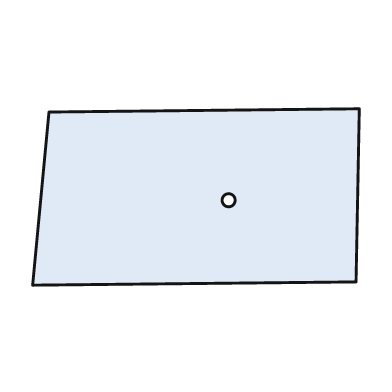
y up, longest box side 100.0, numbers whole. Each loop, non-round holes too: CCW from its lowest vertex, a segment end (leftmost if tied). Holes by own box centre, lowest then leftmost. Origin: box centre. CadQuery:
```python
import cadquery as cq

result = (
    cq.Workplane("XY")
    .moveTo(-50.0, -27.0)
    .lineTo(49.0, -26.0)
    .lineTo(50.0, 27.0)
    .lineTo(-45.0, 26.0)
    .close()
    .moveTo(10.0, -1.0)
    .circle(2.0)
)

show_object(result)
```